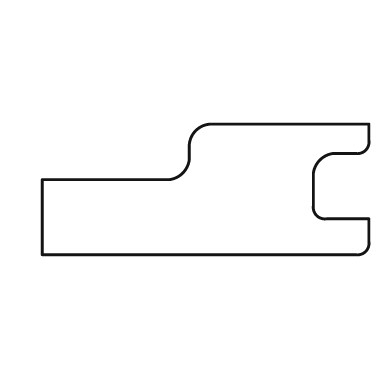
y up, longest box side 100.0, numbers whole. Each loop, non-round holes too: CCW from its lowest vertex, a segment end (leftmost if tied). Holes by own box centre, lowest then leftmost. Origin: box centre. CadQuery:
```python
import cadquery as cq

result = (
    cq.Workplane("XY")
    .moveTo(-50.0, -20.0)
    .lineTo(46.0, -20.0)
    .threePointArc((49.0, -19.0), (50.0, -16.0))
    .lineTo(50.0, -9.0)
    .lineTo(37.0, -9.0)
    .threePointArc((34.0, -8.0), (33.0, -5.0))
    .lineTo(33.0, 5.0)
    .threePointArc((35.0, 9.0), (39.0, 11.0))
    .lineTo(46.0, 11.0)
    .threePointArc((49.0, 12.0), (50.0, 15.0))
    .lineTo(50.0, 20.0)
    .lineTo(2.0, 20.0)
    .threePointArc((-3.0, 18.0), (-5.0, 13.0))
    .lineTo(-5.0, 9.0)
    .threePointArc((-7.0, 5.0), (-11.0, 3.0))
    .lineTo(-50.0, 3.0)
    .close()
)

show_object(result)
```